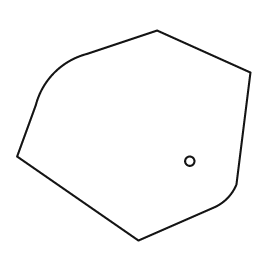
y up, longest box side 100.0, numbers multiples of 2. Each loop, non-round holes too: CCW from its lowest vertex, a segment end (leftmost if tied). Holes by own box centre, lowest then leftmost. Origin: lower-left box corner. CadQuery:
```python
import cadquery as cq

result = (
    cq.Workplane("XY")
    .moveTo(52.0, 0.0)
    .lineTo(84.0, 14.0)
    .threePointArc((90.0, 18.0), (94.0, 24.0))
    .lineTo(100.0, 72.0)
    .lineTo(60.0, 90.0)
    .lineTo(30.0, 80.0)
    .threePointArc((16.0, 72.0), (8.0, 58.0))
    .lineTo(0.0, 36.0)
    .close()
    .moveTo(74.0, 34.0)
    .circle(2.0)
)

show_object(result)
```